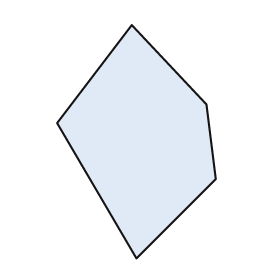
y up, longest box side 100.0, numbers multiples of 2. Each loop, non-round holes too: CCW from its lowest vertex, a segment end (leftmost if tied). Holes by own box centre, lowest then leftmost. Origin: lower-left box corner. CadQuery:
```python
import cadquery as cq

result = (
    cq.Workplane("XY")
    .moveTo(34.0, 0.0)
    .lineTo(68.0, 34.0)
    .lineTo(64.0, 66.0)
    .lineTo(32.0, 100.0)
    .lineTo(0.0, 58.0)
    .close()
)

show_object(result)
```